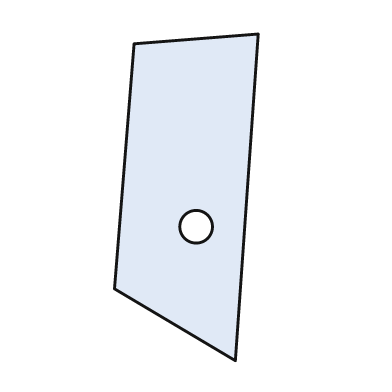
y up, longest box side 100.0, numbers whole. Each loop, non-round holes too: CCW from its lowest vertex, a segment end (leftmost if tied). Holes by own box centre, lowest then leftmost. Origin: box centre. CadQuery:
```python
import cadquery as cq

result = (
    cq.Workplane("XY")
    .moveTo(15.0, -50.0)
    .lineTo(22.0, 50.0)
    .lineTo(-16.0, 47.0)
    .lineTo(-22.0, -28.0)
    .close()
    .moveTo(3.0, -9.0)
    .circle(5.0)
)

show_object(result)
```